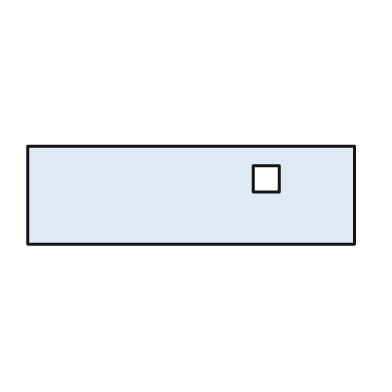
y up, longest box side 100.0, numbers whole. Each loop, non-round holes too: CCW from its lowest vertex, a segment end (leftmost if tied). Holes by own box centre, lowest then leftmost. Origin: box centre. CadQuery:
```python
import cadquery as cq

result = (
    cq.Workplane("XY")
    .moveTo(-50.0, -15.0)
    .lineTo(50.0, -15.0)
    .lineTo(50.0, 15.0)
    .lineTo(-50.0, 15.0)
    .close()
    .moveTo(19.0, 1.0)
    .lineTo(27.0, 1.0)
    .lineTo(27.0, 9.0)
    .lineTo(19.0, 9.0)
    .close()
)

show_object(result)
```